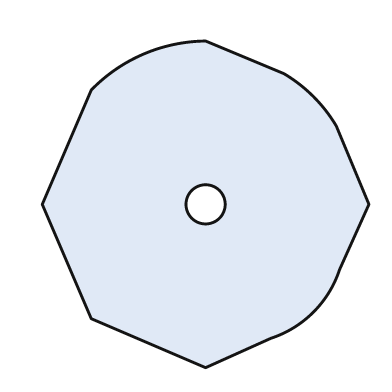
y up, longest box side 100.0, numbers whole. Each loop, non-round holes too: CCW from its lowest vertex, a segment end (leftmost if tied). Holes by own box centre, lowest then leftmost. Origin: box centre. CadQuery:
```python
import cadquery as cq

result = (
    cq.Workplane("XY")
    .moveTo(0.0, -50.0)
    .lineTo(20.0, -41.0)
    .threePointArc((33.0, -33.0), (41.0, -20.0))
    .lineTo(50.0, 0.0)
    .lineTo(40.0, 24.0)
    .threePointArc((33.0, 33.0), (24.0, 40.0))
    .lineTo(0.0, 50.0)
    .threePointArc((-19.0, 46.0), (-35.0, 35.0))
    .lineTo(-50.0, 0.0)
    .lineTo(-35.0, -35.0)
    .close()
    .moveTo(0.0, 0.0)
    .circle(6.0)
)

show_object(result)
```